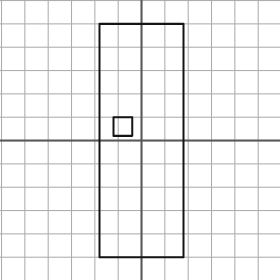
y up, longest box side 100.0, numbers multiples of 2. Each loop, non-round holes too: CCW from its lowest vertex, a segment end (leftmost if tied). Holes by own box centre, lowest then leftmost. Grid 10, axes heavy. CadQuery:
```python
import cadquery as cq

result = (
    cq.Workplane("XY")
    .moveTo(-18.0, -50.0)
    .lineTo(18.0, -50.0)
    .lineTo(18.0, 50.0)
    .lineTo(-18.0, 50.0)
    .close()
    .moveTo(-12.0, 2.0)
    .lineTo(-4.0, 2.0)
    .lineTo(-4.0, 10.0)
    .lineTo(-12.0, 10.0)
    .close()
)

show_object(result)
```